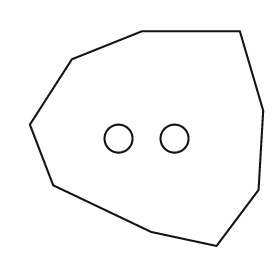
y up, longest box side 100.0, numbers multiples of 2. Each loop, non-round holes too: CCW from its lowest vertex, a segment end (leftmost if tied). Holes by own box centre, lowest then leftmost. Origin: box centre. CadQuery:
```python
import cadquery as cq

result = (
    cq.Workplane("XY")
    .moveTo(30.0, -46.0)
    .lineTo(48.0, -22.0)
    .lineTo(50.0, 12.0)
    .lineTo(40.0, 46.0)
    .lineTo(-2.0, 46.0)
    .lineTo(-32.0, 34.0)
    .lineTo(-50.0, 6.0)
    .lineTo(-40.0, -20.0)
    .lineTo(2.0, -40.0)
    .close()
    .moveTo(-12.0, 0.0)
    .circle(6.0)
    .moveTo(12.0, 0.0)
    .circle(6.0)
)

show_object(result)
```